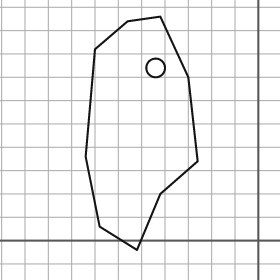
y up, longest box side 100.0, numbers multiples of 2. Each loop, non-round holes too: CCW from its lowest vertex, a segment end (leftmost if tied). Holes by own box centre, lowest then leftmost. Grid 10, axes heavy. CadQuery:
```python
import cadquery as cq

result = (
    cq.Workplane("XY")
    .moveTo(-52.0, -4.0)
    .lineTo(-42.0, 20.0)
    .lineTo(-26.0, 34.0)
    .lineTo(-30.0, 70.0)
    .lineTo(-42.0, 96.0)
    .lineTo(-56.0, 94.0)
    .lineTo(-70.0, 82.0)
    .lineTo(-74.0, 36.0)
    .lineTo(-68.0, 6.0)
    .close()
    .moveTo(-44.0, 74.0)
    .circle(4.0)
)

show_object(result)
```